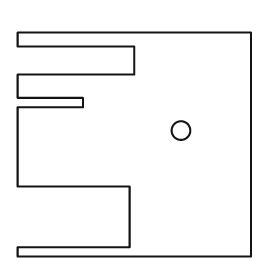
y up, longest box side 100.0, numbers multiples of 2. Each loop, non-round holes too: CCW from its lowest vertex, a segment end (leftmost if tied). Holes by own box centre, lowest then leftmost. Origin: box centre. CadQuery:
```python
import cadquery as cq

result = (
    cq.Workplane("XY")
    .moveTo(-50.0, -48.0)
    .lineTo(50.0, -48.0)
    .lineTo(50.0, 48.0)
    .lineTo(-50.0, 48.0)
    .lineTo(-50.0, 42.0)
    .lineTo(0.0, 42.0)
    .lineTo(0.0, 30.0)
    .lineTo(-50.0, 30.0)
    .lineTo(-50.0, 20.0)
    .lineTo(-22.0, 20.0)
    .lineTo(-22.0, 16.0)
    .lineTo(-50.0, 16.0)
    .lineTo(-50.0, -18.0)
    .lineTo(-2.0, -18.0)
    .lineTo(-2.0, -44.0)
    .lineTo(-50.0, -44.0)
    .close()
    .moveTo(20.0, 6.0)
    .circle(4.0)
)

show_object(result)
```